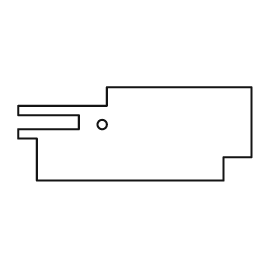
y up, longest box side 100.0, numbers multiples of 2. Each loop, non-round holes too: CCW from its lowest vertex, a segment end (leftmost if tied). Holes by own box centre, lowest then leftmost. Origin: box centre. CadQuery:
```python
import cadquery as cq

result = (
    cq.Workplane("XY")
    .moveTo(-42.0, -20.0)
    .lineTo(38.0, -20.0)
    .lineTo(38.0, -10.0)
    .lineTo(50.0, -10.0)
    .lineTo(50.0, 20.0)
    .lineTo(-12.0, 20.0)
    .lineTo(-12.0, 12.0)
    .lineTo(-50.0, 12.0)
    .lineTo(-50.0, 8.0)
    .lineTo(-24.0, 8.0)
    .lineTo(-24.0, 2.0)
    .lineTo(-50.0, 2.0)
    .lineTo(-50.0, -2.0)
    .lineTo(-42.0, -2.0)
    .close()
    .moveTo(-14.0, 4.0)
    .circle(2.0)
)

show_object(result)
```